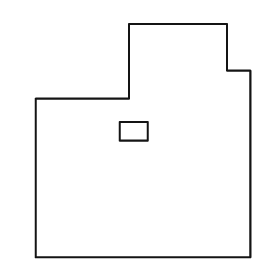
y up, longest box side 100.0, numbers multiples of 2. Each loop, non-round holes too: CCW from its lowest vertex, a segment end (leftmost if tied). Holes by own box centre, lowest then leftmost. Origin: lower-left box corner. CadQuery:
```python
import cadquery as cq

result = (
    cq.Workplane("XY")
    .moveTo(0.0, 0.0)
    .lineTo(92.0, 0.0)
    .lineTo(92.0, 80.0)
    .lineTo(82.0, 80.0)
    .lineTo(82.0, 100.0)
    .lineTo(40.0, 100.0)
    .lineTo(40.0, 68.0)
    .lineTo(0.0, 68.0)
    .close()
    .moveTo(36.0, 50.0)
    .lineTo(48.0, 50.0)
    .lineTo(48.0, 58.0)
    .lineTo(36.0, 58.0)
    .close()
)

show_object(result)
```